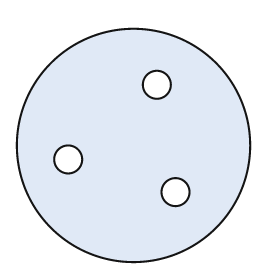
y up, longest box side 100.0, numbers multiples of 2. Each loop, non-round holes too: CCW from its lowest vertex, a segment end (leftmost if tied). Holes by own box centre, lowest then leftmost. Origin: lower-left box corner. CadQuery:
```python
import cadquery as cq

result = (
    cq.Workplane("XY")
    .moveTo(50.0, 50.0)
    .circle(50.0)
    .moveTo(68.0, 30.0)
    .circle(6.0)
    .moveTo(22.0, 44.0)
    .circle(6.0)
    .moveTo(60.0, 76.0)
    .circle(6.0)
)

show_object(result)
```